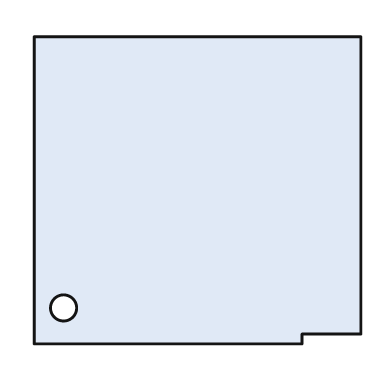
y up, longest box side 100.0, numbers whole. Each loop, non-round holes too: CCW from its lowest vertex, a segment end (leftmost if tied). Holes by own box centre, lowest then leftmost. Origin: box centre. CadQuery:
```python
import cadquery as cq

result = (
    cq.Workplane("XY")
    .moveTo(-50.0, -47.0)
    .lineTo(32.0, -47.0)
    .lineTo(32.0, -44.0)
    .lineTo(50.0, -44.0)
    .lineTo(50.0, 47.0)
    .lineTo(-50.0, 47.0)
    .close()
    .moveTo(-41.0, -36.0)
    .circle(4.0)
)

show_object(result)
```